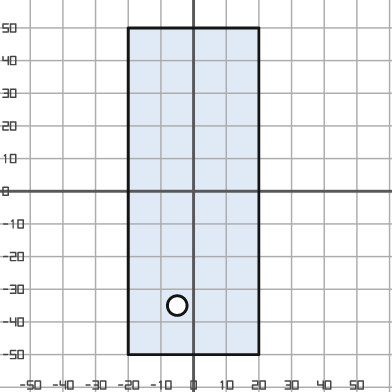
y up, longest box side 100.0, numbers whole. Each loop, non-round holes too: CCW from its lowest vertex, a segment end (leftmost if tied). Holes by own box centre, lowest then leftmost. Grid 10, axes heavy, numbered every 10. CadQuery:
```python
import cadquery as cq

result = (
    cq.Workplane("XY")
    .moveTo(-20.0, -50.0)
    .lineTo(20.0, -50.0)
    .lineTo(20.0, 50.0)
    .lineTo(-20.0, 50.0)
    .close()
    .moveTo(-5.0, -35.0)
    .circle(3.0)
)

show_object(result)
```